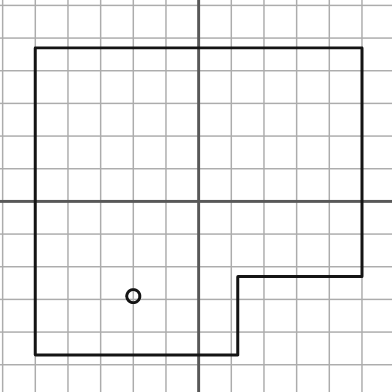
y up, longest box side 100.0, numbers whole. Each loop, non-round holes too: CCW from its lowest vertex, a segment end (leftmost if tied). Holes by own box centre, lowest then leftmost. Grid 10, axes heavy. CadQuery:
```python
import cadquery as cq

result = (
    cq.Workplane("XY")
    .moveTo(-50.0, -47.0)
    .lineTo(12.0, -47.0)
    .lineTo(12.0, -23.0)
    .lineTo(50.0, -23.0)
    .lineTo(50.0, 47.0)
    .lineTo(-50.0, 47.0)
    .close()
    .moveTo(-20.0, -29.0)
    .circle(2.0)
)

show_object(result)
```